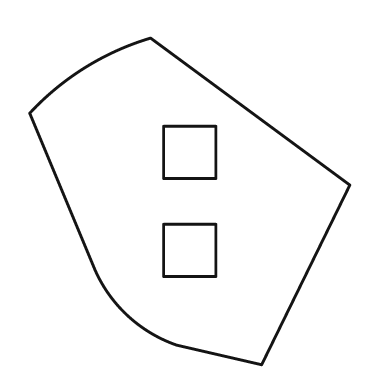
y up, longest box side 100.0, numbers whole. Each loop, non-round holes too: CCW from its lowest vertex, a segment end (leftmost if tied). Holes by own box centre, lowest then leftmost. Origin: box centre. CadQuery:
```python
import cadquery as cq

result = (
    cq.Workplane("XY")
    .moveTo(22.0, -50.0)
    .lineTo(49.0, 5.0)
    .lineTo(-12.0, 50.0)
    .threePointArc((-32.0, 41.0), (-49.0, 27.0))
    .lineTo(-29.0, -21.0)
    .threePointArc((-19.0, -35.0), (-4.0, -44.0))
    .close()
    .moveTo(-8.0, -23.0)
    .lineTo(8.0, -23.0)
    .lineTo(8.0, -7.0)
    .lineTo(-8.0, -7.0)
    .close()
    .moveTo(-8.0, 7.0)
    .lineTo(8.0, 7.0)
    .lineTo(8.0, 23.0)
    .lineTo(-8.0, 23.0)
    .close()
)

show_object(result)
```